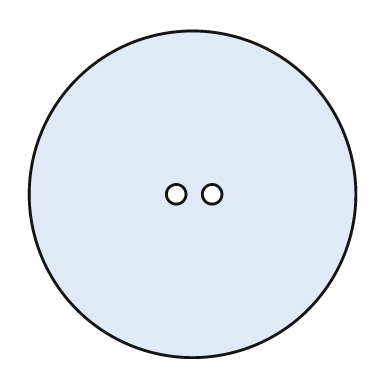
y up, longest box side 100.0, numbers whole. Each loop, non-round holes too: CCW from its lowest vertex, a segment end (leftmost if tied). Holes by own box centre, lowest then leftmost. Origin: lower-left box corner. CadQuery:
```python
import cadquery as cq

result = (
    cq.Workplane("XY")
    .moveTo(50.0, 50.0)
    .circle(50.0)
    .moveTo(45.0, 50.0)
    .circle(3.0)
    .moveTo(56.0, 50.0)
    .circle(3.0)
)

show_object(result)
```